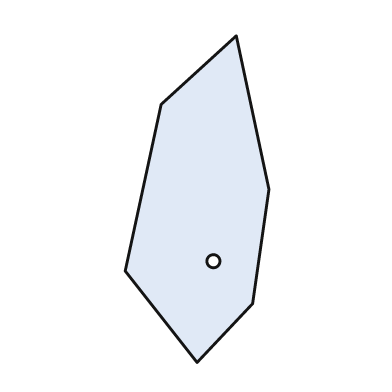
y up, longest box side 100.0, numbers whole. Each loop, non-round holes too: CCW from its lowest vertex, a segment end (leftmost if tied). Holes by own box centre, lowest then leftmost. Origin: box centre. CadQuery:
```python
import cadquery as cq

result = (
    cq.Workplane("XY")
    .moveTo(0.0, -50.0)
    .lineTo(17.0, -32.0)
    .lineTo(22.0, 3.0)
    .lineTo(12.0, 50.0)
    .lineTo(-11.0, 29.0)
    .lineTo(-22.0, -22.0)
    .close()
    .moveTo(5.0, -19.0)
    .circle(2.0)
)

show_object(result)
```